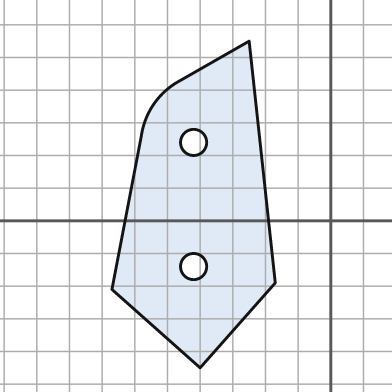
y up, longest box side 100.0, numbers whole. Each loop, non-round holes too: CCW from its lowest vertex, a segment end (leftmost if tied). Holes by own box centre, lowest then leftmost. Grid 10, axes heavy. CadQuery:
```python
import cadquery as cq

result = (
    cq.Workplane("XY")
    .moveTo(-40.0, -45.0)
    .lineTo(-17.0, -19.0)
    .lineTo(-25.0, 55.0)
    .lineTo(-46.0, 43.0)
    .threePointArc((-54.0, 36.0), (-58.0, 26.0))
    .lineTo(-67.0, -21.0)
    .close()
    .moveTo(-42.0, -14.0)
    .circle(4.0)
    .moveTo(-42.0, 24.0)
    .circle(4.0)
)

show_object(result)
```